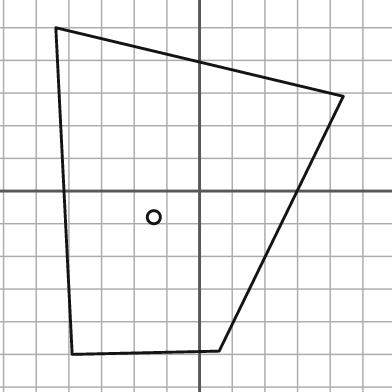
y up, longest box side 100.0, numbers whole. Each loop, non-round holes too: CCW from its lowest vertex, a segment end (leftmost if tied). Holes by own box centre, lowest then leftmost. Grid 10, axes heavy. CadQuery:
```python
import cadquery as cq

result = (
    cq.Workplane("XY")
    .moveTo(-39.0, -50.0)
    .lineTo(6.0, -49.0)
    .lineTo(44.0, 29.0)
    .lineTo(-44.0, 50.0)
    .close()
    .moveTo(-14.0, -8.0)
    .circle(2.0)
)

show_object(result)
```